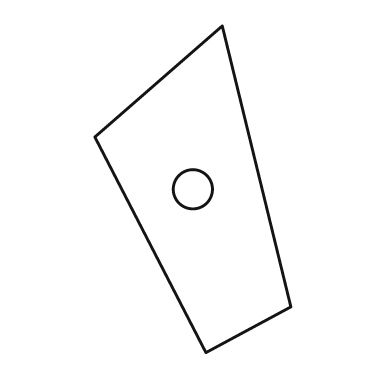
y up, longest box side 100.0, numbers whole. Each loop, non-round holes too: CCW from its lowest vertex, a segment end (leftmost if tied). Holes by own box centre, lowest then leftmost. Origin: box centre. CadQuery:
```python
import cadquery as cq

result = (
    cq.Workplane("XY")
    .moveTo(4.0, -50.0)
    .lineTo(30.0, -36.0)
    .lineTo(9.0, 50.0)
    .lineTo(-30.0, 16.0)
    .close()
    .moveTo(0.0, 0.0)
    .circle(6.0)
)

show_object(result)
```